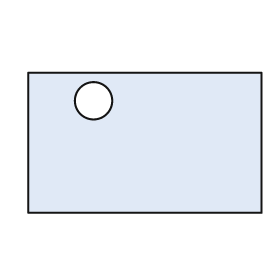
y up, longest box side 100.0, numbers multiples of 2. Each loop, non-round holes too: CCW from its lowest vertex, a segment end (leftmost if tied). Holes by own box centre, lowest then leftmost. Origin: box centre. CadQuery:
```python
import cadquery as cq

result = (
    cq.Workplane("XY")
    .moveTo(-50.0, -30.0)
    .lineTo(50.0, -30.0)
    .lineTo(50.0, 30.0)
    .lineTo(-50.0, 30.0)
    .close()
    .moveTo(-22.0, 18.0)
    .circle(8.0)
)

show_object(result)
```